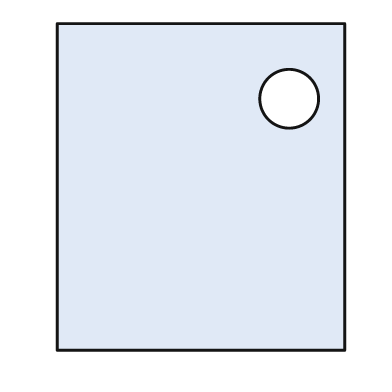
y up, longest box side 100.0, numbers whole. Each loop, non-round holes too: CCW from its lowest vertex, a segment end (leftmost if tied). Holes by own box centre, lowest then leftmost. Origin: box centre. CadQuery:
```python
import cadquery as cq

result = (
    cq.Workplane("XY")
    .moveTo(-44.0, -50.0)
    .lineTo(44.0, -50.0)
    .lineTo(44.0, 50.0)
    .lineTo(-44.0, 50.0)
    .close()
    .moveTo(27.0, 27.0)
    .circle(9.0)
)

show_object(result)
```